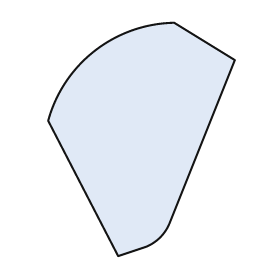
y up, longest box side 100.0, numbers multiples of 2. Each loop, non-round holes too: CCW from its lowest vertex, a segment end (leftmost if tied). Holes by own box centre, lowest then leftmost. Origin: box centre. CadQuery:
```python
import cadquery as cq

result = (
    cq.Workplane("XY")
    .moveTo(-10.0, -50.0)
    .lineTo(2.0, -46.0)
    .threePointArc((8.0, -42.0), (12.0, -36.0))
    .lineTo(40.0, 34.0)
    .lineTo(14.0, 50.0)
    .threePointArc((-20.0, 38.0), (-40.0, 8.0))
    .close()
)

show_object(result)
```